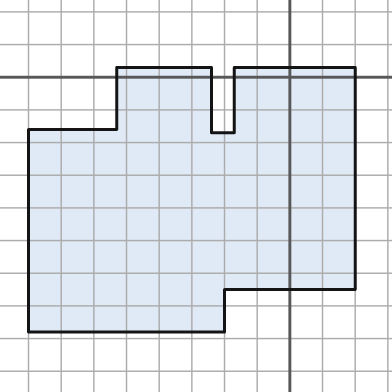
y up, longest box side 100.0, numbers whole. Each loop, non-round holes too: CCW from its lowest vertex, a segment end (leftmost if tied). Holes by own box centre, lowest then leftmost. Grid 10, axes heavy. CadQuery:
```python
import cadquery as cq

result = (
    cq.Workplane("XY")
    .moveTo(-80.0, -78.0)
    .lineTo(-20.0, -78.0)
    .lineTo(-20.0, -65.0)
    .lineTo(20.0, -65.0)
    .lineTo(20.0, 3.0)
    .lineTo(-17.0, 3.0)
    .lineTo(-17.0, -17.0)
    .lineTo(-24.0, -17.0)
    .lineTo(-24.0, 3.0)
    .lineTo(-53.0, 3.0)
    .lineTo(-53.0, -16.0)
    .lineTo(-80.0, -16.0)
    .close()
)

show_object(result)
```